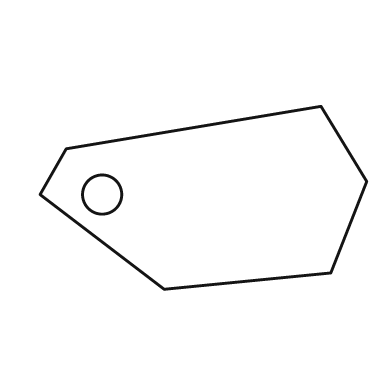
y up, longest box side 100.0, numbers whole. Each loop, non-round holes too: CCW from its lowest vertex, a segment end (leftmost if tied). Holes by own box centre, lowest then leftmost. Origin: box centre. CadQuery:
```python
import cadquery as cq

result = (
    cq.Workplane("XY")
    .moveTo(-12.0, -28.0)
    .lineTo(39.0, -23.0)
    .lineTo(50.0, 5.0)
    .lineTo(36.0, 28.0)
    .lineTo(-42.0, 15.0)
    .lineTo(-50.0, 1.0)
    .close()
    .moveTo(-31.0, 1.0)
    .circle(6.0)
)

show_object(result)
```